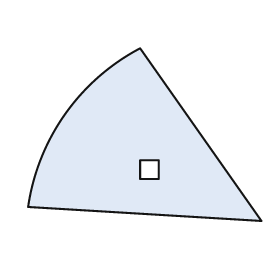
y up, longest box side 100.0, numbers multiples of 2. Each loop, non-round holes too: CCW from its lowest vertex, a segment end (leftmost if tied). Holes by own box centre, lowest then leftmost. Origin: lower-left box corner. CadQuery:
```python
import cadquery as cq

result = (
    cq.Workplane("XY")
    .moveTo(100.0, 0.0)
    .lineTo(48.0, 74.0)
    .threePointArc((16.0, 46.0), (0.0, 6.0))
    .close()
    .moveTo(48.0, 18.0)
    .lineTo(56.0, 18.0)
    .lineTo(56.0, 26.0)
    .lineTo(48.0, 26.0)
    .close()
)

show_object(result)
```